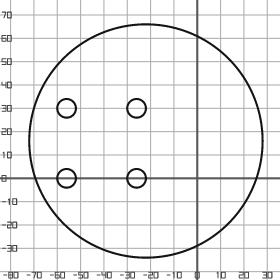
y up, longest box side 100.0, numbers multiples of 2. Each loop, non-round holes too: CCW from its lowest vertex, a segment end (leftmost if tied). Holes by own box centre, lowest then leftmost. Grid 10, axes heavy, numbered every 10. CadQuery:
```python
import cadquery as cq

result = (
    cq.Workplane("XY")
    .moveTo(-22.0, 16.0)
    .circle(50.0)
    .moveTo(-56.0, 0.0)
    .circle(4.0)
    .moveTo(-26.0, 0.0)
    .circle(4.0)
    .moveTo(-56.0, 30.0)
    .circle(4.0)
    .moveTo(-26.0, 30.0)
    .circle(4.0)
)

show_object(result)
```